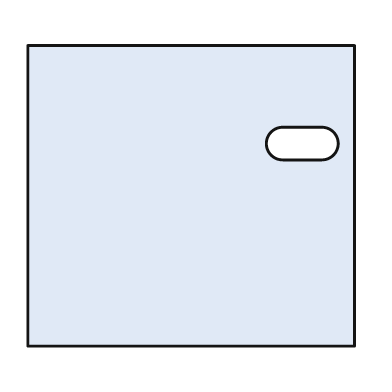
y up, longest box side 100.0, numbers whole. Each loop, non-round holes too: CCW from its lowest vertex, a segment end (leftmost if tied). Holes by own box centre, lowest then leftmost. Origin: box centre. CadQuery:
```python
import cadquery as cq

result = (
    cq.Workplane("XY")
    .moveTo(-50.0, -46.0)
    .lineTo(50.0, -46.0)
    .lineTo(50.0, 46.0)
    .lineTo(-50.0, 46.0)
    .close()
    .moveTo(28.0, 11.0)
    .lineTo(40.0, 11.0)
    .threePointArc((45.0, 16.0), (40.0, 21.0))
    .lineTo(28.0, 21.0)
    .threePointArc((23.0, 16.0), (28.0, 11.0))
    .close()
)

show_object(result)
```